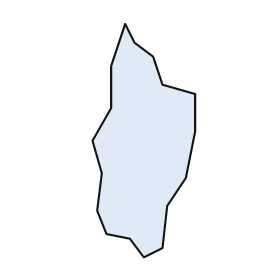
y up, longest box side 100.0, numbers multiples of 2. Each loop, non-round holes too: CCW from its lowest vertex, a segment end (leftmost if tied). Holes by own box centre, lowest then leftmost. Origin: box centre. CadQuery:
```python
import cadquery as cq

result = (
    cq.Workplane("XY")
    .moveTo(0.0, -50.0)
    .lineTo(8.0, -46.0)
    .lineTo(10.0, -28.0)
    .lineTo(18.0, -16.0)
    .lineTo(22.0, 4.0)
    .lineTo(22.0, 20.0)
    .lineTo(8.0, 24.0)
    .lineTo(4.0, 36.0)
    .lineTo(-4.0, 42.0)
    .lineTo(-8.0, 50.0)
    .lineTo(-14.0, 32.0)
    .lineTo(-14.0, 14.0)
    .lineTo(-22.0, 0.0)
    .lineTo(-18.0, -14.0)
    .lineTo(-20.0, -30.0)
    .lineTo(-16.0, -40.0)
    .lineTo(-6.0, -42.0)
    .close()
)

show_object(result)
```